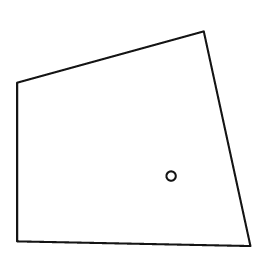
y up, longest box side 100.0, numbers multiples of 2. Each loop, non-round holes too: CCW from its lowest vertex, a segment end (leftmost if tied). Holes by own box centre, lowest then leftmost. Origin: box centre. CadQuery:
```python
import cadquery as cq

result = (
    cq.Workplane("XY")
    .moveTo(50.0, -46.0)
    .lineTo(30.0, 46.0)
    .lineTo(-50.0, 24.0)
    .lineTo(-50.0, -44.0)
    .close()
    .moveTo(16.0, -16.0)
    .circle(2.0)
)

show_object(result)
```